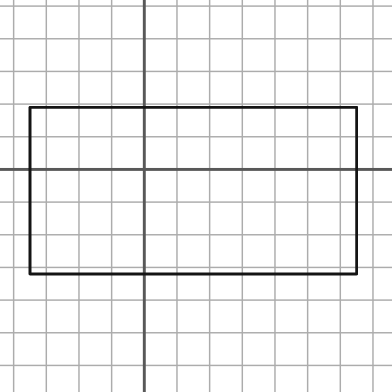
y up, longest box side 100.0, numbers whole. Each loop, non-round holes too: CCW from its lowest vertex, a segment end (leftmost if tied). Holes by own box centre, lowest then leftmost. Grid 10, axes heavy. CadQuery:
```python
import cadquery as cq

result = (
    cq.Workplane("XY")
    .moveTo(-35.0, -32.0)
    .lineTo(65.0, -32.0)
    .lineTo(65.0, 19.0)
    .lineTo(-35.0, 19.0)
    .close()
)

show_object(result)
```